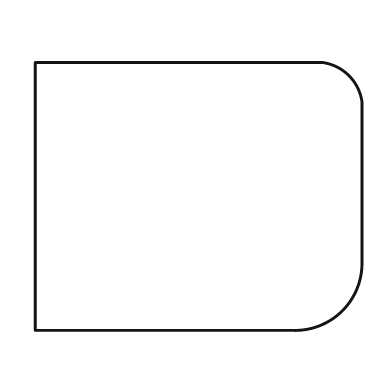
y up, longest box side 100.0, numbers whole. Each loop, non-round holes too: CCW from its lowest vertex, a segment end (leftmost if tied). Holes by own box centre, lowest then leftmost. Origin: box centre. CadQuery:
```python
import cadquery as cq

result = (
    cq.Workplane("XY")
    .moveTo(-50.0, -41.0)
    .lineTo(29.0, -41.0)
    .threePointArc((44.0, -35.0), (50.0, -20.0))
    .lineTo(50.0, 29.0)
    .threePointArc((46.0, 37.0), (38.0, 41.0))
    .lineTo(-50.0, 41.0)
    .close()
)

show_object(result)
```